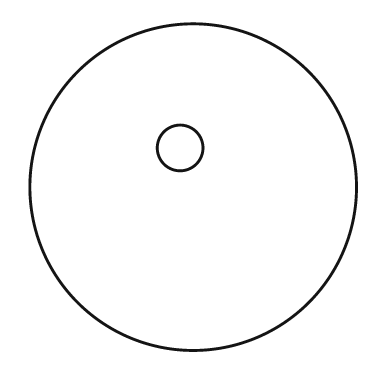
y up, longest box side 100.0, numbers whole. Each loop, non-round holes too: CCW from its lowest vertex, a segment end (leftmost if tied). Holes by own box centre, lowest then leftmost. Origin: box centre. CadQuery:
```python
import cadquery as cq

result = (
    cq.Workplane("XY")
    .moveTo(0.0, 0.0)
    .circle(50.0)
    .moveTo(-4.0, 12.0)
    .circle(7.0)
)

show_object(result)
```